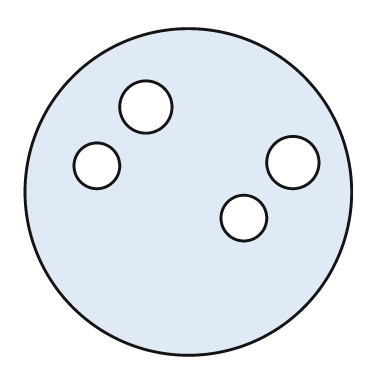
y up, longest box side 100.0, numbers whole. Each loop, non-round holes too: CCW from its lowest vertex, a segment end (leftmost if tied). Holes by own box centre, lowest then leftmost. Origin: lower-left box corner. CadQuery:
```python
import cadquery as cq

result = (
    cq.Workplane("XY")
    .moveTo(50.0, 50.0)
    .circle(50.0)
    .moveTo(67.0, 42.0)
    .circle(7.0)
    .moveTo(22.0, 58.0)
    .circle(7.0)
    .moveTo(82.0, 59.0)
    .circle(8.0)
    .moveTo(37.0, 76.0)
    .circle(8.0)
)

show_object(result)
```